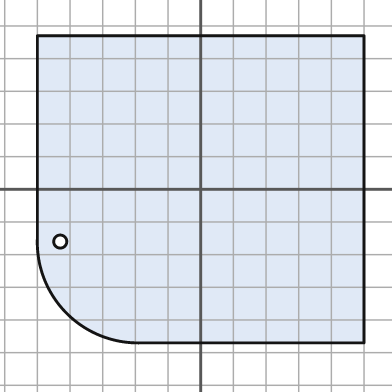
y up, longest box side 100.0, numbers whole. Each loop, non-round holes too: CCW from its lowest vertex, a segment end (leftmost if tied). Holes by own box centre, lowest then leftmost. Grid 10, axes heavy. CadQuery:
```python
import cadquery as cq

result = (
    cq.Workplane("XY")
    .moveTo(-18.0, -47.0)
    .lineTo(50.0, -47.0)
    .lineTo(50.0, 47.0)
    .lineTo(-50.0, 47.0)
    .lineTo(-50.0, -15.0)
    .threePointArc((-41.0, -38.0), (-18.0, -47.0))
    .close()
    .moveTo(-43.0, -16.0)
    .circle(2.0)
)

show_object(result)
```